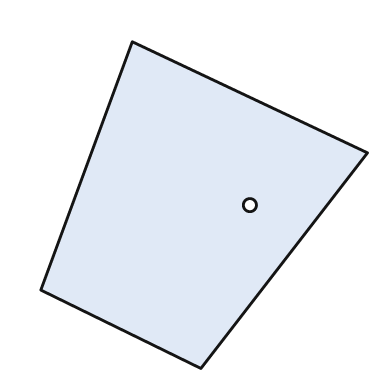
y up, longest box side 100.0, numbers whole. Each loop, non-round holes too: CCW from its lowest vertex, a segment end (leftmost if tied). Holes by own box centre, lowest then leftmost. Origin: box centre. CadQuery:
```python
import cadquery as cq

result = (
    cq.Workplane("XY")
    .moveTo(-1.0, -50.0)
    .lineTo(50.0, 16.0)
    .lineTo(-22.0, 50.0)
    .lineTo(-50.0, -26.0)
    .close()
    .moveTo(14.0, 0.0)
    .circle(2.0)
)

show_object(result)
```